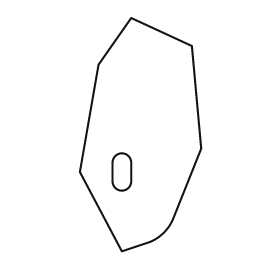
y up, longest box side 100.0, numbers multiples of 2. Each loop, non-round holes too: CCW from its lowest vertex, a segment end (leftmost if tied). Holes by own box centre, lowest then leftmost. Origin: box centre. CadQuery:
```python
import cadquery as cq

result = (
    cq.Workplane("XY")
    .moveTo(-8.0, -50.0)
    .lineTo(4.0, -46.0)
    .threePointArc((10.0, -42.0), (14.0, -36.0))
    .lineTo(26.0, -6.0)
    .lineTo(22.0, 38.0)
    .lineTo(-4.0, 50.0)
    .lineTo(-18.0, 30.0)
    .lineTo(-26.0, -16.0)
    .close()
    .moveTo(-12.0, -20.0)
    .threePointArc((-8.0, -24.0), (-4.0, -20.0))
    .lineTo(-4.0, -12.0)
    .threePointArc((-8.0, -8.0), (-12.0, -12.0))
    .close()
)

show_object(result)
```